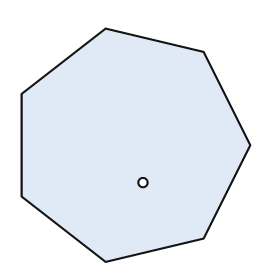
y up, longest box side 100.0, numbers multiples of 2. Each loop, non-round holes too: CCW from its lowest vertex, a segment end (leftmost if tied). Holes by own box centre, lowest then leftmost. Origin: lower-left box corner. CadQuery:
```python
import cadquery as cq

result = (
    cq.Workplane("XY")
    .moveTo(36.0, 0.0)
    .lineTo(78.0, 10.0)
    .lineTo(98.0, 50.0)
    .lineTo(78.0, 90.0)
    .lineTo(36.0, 100.0)
    .lineTo(0.0, 72.0)
    .lineTo(0.0, 28.0)
    .close()
    .moveTo(52.0, 34.0)
    .circle(2.0)
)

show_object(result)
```